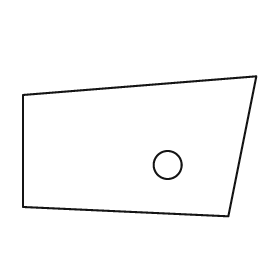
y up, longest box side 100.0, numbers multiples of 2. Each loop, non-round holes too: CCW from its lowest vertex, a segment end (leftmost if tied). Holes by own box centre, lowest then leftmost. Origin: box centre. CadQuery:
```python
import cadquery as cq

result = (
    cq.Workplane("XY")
    .moveTo(38.0, -30.0)
    .lineTo(50.0, 30.0)
    .lineTo(-50.0, 22.0)
    .lineTo(-50.0, -26.0)
    .close()
    .moveTo(12.0, -8.0)
    .circle(6.0)
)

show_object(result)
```